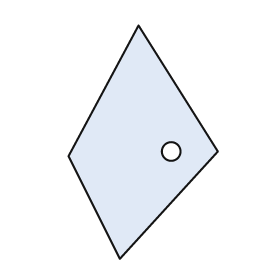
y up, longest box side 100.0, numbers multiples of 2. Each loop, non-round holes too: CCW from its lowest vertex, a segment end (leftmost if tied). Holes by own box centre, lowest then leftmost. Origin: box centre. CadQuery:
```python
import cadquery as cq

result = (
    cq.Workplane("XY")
    .moveTo(-10.0, -50.0)
    .lineTo(32.0, -4.0)
    .lineTo(-2.0, 50.0)
    .lineTo(-32.0, -6.0)
    .close()
    .moveTo(12.0, -4.0)
    .circle(4.0)
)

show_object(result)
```